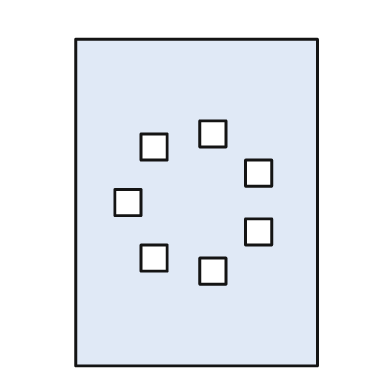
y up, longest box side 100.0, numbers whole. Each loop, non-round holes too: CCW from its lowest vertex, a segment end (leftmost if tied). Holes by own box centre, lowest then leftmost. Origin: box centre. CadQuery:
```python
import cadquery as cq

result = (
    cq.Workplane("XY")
    .moveTo(-37.0, -50.0)
    .lineTo(37.0, -50.0)
    .lineTo(37.0, 50.0)
    .lineTo(-37.0, 50.0)
    .close()
    .moveTo(1.0, -25.0)
    .lineTo(9.0, -25.0)
    .lineTo(9.0, -17.0)
    .lineTo(1.0, -17.0)
    .close()
    .moveTo(-17.0, -21.0)
    .lineTo(-9.0, -21.0)
    .lineTo(-9.0, -13.0)
    .lineTo(-17.0, -13.0)
    .close()
    .moveTo(15.0, -13.0)
    .lineTo(23.0, -13.0)
    .lineTo(23.0, -5.0)
    .lineTo(15.0, -5.0)
    .close()
    .moveTo(-25.0, -4.0)
    .lineTo(-17.0, -4.0)
    .lineTo(-17.0, 4.0)
    .lineTo(-25.0, 4.0)
    .close()
    .moveTo(15.0, 5.0)
    .lineTo(23.0, 5.0)
    .lineTo(23.0, 13.0)
    .lineTo(15.0, 13.0)
    .close()
    .moveTo(-17.0, 13.0)
    .lineTo(-9.0, 13.0)
    .lineTo(-9.0, 21.0)
    .lineTo(-17.0, 21.0)
    .close()
    .moveTo(1.0, 17.0)
    .lineTo(9.0, 17.0)
    .lineTo(9.0, 25.0)
    .lineTo(1.0, 25.0)
    .close()
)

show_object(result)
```